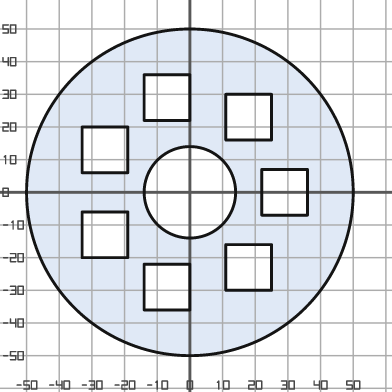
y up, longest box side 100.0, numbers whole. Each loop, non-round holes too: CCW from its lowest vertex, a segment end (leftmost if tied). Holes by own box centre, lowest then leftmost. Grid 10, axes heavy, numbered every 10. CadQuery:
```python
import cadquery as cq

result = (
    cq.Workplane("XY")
    .moveTo(0.0, 0.0)
    .circle(50.0)
    .moveTo(-14.0, -36.0)
    .lineTo(0.0, -36.0)
    .lineTo(0.0, -22.0)
    .lineTo(-14.0, -22.0)
    .close()
    .moveTo(11.0, -30.0)
    .lineTo(25.0, -30.0)
    .lineTo(25.0, -16.0)
    .lineTo(11.0, -16.0)
    .close()
    .moveTo(-33.0, -20.0)
    .lineTo(-19.0, -20.0)
    .lineTo(-19.0, -6.0)
    .lineTo(-33.0, -6.0)
    .close()
    .moveTo(0.0, 0.0)
    .circle(14.0)
    .moveTo(22.0, -7.0)
    .lineTo(36.0, -7.0)
    .lineTo(36.0, 7.0)
    .lineTo(22.0, 7.0)
    .close()
    .moveTo(-33.0, 6.0)
    .lineTo(-19.0, 6.0)
    .lineTo(-19.0, 20.0)
    .lineTo(-33.0, 20.0)
    .close()
    .moveTo(11.0, 16.0)
    .lineTo(25.0, 16.0)
    .lineTo(25.0, 30.0)
    .lineTo(11.0, 30.0)
    .close()
    .moveTo(-14.0, 22.0)
    .lineTo(0.0, 22.0)
    .lineTo(0.0, 36.0)
    .lineTo(-14.0, 36.0)
    .close()
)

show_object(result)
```